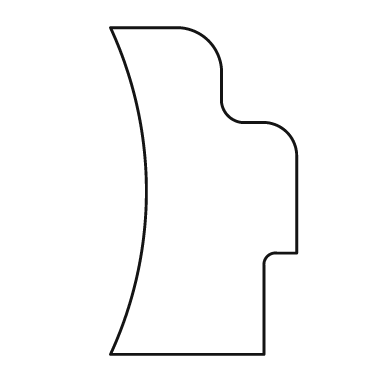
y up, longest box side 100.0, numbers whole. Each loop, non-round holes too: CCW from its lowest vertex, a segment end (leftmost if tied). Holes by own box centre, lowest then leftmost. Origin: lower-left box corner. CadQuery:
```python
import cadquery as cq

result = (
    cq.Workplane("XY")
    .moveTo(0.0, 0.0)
    .lineTo(47.0, 0.0)
    .lineTo(47.0, 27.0)
    .threePointArc((48.0, 30.0), (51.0, 31.0))
    .lineTo(57.0, 31.0)
    .lineTo(57.0, 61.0)
    .threePointArc((54.0, 68.0), (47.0, 71.0))
    .lineTo(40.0, 71.0)
    .threePointArc((36.0, 73.0), (34.0, 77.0))
    .lineTo(34.0, 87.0)
    .threePointArc((30.0, 96.0), (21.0, 100.0))
    .lineTo(0.0, 100.0)
    .threePointArc((11.0, 50.0), (0.0, 0.0))
    .close()
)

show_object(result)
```